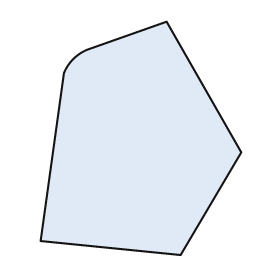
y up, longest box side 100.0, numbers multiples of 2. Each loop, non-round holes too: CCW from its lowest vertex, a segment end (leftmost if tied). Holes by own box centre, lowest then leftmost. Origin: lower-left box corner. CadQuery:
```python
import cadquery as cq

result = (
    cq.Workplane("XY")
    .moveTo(60.0, 0.0)
    .lineTo(86.0, 44.0)
    .lineTo(54.0, 100.0)
    .lineTo(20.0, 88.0)
    .threePointArc((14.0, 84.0), (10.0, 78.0))
    .lineTo(0.0, 6.0)
    .close()
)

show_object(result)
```